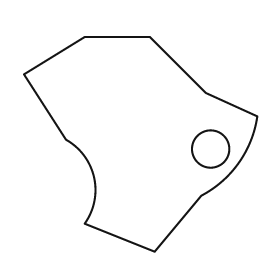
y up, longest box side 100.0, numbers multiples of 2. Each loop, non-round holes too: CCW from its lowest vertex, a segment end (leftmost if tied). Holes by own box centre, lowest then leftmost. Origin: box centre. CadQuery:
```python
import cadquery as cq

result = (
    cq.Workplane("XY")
    .moveTo(6.0, -46.0)
    .lineTo(26.0, -22.0)
    .threePointArc((42.0, -8.0), (50.0, 12.0))
    .lineTo(28.0, 22.0)
    .lineTo(4.0, 46.0)
    .lineTo(-24.0, 46.0)
    .lineTo(-50.0, 30.0)
    .lineTo(-32.0, 2.0)
    .threePointArc((-20.0, -14.0), (-24.0, -34.0))
    .close()
    .moveTo(30.0, -2.0)
    .circle(8.0)
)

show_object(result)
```